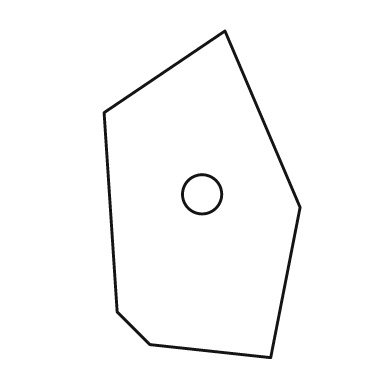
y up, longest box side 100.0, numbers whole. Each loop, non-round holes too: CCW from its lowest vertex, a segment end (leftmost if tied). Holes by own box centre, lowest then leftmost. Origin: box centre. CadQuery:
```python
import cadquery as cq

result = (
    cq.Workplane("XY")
    .moveTo(21.0, -50.0)
    .lineTo(30.0, -4.0)
    .lineTo(7.0, 50.0)
    .lineTo(-30.0, 25.0)
    .lineTo(-26.0, -36.0)
    .lineTo(-16.0, -46.0)
    .close()
    .moveTo(0.0, 0.0)
    .circle(6.0)
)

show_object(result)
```